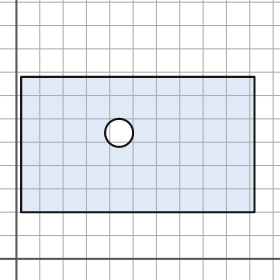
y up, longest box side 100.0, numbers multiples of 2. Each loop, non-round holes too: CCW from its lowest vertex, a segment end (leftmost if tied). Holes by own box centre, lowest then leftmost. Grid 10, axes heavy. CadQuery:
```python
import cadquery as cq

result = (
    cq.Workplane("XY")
    .moveTo(2.0, 20.0)
    .lineTo(102.0, 20.0)
    .lineTo(102.0, 78.0)
    .lineTo(2.0, 78.0)
    .close()
    .moveTo(44.0, 54.0)
    .circle(6.0)
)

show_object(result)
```